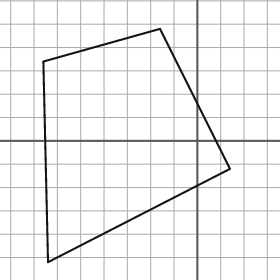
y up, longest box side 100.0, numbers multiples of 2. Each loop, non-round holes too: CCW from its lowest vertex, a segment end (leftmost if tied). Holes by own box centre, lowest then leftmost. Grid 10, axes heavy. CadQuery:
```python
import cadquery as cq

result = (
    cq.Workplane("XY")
    .moveTo(-64.0, -52.0)
    .lineTo(14.0, -12.0)
    .lineTo(-16.0, 48.0)
    .lineTo(-66.0, 34.0)
    .close()
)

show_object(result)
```